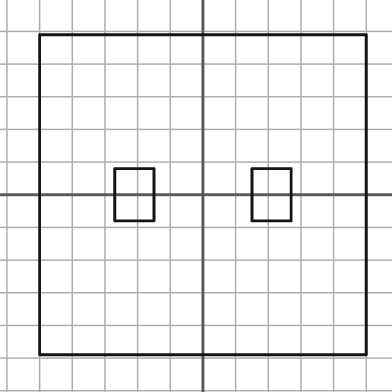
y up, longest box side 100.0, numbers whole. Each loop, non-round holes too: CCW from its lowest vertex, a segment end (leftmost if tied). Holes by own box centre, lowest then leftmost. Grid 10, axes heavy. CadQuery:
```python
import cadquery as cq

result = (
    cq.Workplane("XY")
    .moveTo(-50.0, -49.0)
    .lineTo(50.0, -49.0)
    .lineTo(50.0, 49.0)
    .lineTo(-50.0, 49.0)
    .close()
    .moveTo(-27.0, -8.0)
    .lineTo(-15.0, -8.0)
    .lineTo(-15.0, 8.0)
    .lineTo(-27.0, 8.0)
    .close()
    .moveTo(15.0, -8.0)
    .lineTo(27.0, -8.0)
    .lineTo(27.0, 8.0)
    .lineTo(15.0, 8.0)
    .close()
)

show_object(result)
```